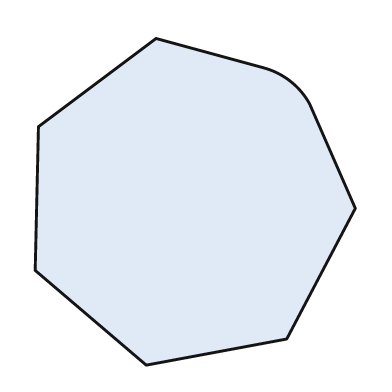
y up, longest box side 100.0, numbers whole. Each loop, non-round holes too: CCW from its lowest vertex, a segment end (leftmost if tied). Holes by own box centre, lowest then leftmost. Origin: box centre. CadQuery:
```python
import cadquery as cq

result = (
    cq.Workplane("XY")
    .moveTo(-15.0, -50.0)
    .lineTo(28.0, -42.0)
    .lineTo(49.0, -2.0)
    .lineTo(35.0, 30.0)
    .threePointArc((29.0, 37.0), (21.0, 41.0))
    .lineTo(-12.0, 50.0)
    .lineTo(-48.0, 23.0)
    .lineTo(-49.0, -21.0)
    .close()
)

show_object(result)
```